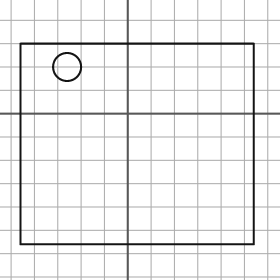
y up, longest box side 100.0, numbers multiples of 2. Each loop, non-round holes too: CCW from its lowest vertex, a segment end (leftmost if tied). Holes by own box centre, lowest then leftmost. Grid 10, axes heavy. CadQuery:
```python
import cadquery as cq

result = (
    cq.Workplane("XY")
    .moveTo(-46.0, -56.0)
    .lineTo(54.0, -56.0)
    .lineTo(54.0, 30.0)
    .lineTo(-46.0, 30.0)
    .close()
    .moveTo(-26.0, 20.0)
    .circle(6.0)
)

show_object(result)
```